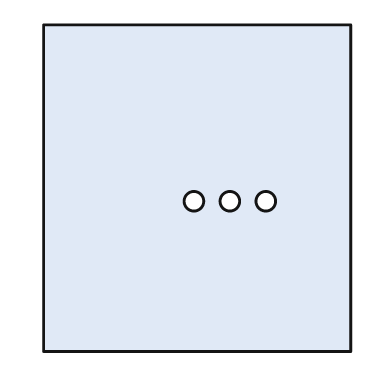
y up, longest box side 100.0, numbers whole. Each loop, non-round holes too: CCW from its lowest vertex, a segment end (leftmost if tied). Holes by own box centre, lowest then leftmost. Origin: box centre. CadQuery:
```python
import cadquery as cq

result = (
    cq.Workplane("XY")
    .moveTo(-47.0, -50.0)
    .lineTo(47.0, -50.0)
    .lineTo(47.0, 50.0)
    .lineTo(-47.0, 50.0)
    .close()
    .moveTo(-1.0, -4.0)
    .circle(3.0)
    .moveTo(10.0, -4.0)
    .circle(3.0)
    .moveTo(21.0, -4.0)
    .circle(3.0)
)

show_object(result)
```